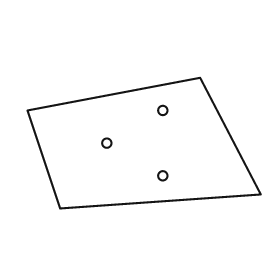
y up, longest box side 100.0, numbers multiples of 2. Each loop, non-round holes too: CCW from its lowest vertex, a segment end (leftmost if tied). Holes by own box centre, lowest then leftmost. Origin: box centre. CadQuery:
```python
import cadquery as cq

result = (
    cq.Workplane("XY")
    .moveTo(-36.0, -28.0)
    .lineTo(50.0, -22.0)
    .lineTo(24.0, 28.0)
    .lineTo(-50.0, 14.0)
    .close()
    .moveTo(8.0, -14.0)
    .circle(2.0)
    .moveTo(-16.0, 0.0)
    .circle(2.0)
    .moveTo(8.0, 14.0)
    .circle(2.0)
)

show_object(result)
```